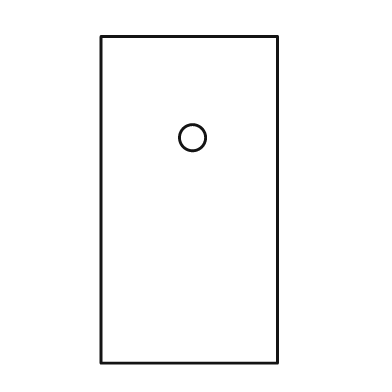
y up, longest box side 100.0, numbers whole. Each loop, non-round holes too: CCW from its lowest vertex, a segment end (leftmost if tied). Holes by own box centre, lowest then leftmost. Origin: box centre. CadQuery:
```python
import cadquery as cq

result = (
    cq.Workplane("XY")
    .moveTo(-27.0, -50.0)
    .lineTo(27.0, -50.0)
    .lineTo(27.0, 50.0)
    .lineTo(-27.0, 50.0)
    .close()
    .moveTo(1.0, 19.0)
    .circle(4.0)
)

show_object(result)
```